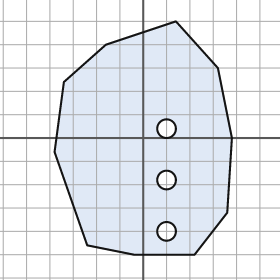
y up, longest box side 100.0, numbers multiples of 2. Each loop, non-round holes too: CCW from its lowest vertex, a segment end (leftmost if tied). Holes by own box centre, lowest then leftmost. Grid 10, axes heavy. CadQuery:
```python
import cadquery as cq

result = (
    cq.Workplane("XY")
    .moveTo(-4.0, -50.0)
    .lineTo(22.0, -50.0)
    .lineTo(36.0, -32.0)
    .lineTo(38.0, 0.0)
    .lineTo(32.0, 30.0)
    .lineTo(14.0, 50.0)
    .lineTo(-16.0, 40.0)
    .lineTo(-34.0, 24.0)
    .lineTo(-38.0, -6.0)
    .lineTo(-24.0, -46.0)
    .close()
    .moveTo(10.0, -40.0)
    .circle(4.0)
    .moveTo(10.0, -18.0)
    .circle(4.0)
    .moveTo(10.0, 4.0)
    .circle(4.0)
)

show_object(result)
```